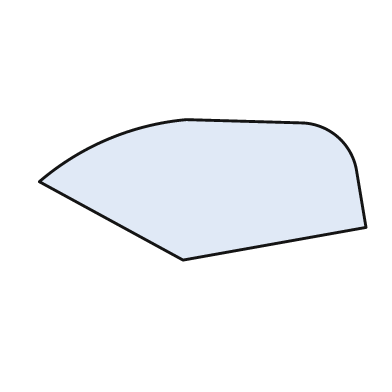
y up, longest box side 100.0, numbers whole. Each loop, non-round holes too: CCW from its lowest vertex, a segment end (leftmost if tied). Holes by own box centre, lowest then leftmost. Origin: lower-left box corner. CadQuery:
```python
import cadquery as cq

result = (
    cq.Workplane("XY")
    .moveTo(44.0, 0.0)
    .lineTo(100.0, 10.0)
    .lineTo(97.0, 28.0)
    .threePointArc((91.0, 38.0), (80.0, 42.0))
    .lineTo(45.0, 43.0)
    .threePointArc((21.0, 37.0), (0.0, 24.0))
    .close()
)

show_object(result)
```